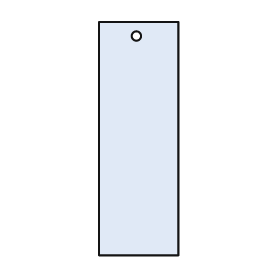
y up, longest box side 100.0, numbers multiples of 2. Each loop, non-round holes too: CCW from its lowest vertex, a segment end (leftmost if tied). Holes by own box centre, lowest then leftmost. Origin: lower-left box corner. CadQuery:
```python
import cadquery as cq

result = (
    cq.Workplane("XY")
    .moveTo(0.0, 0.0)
    .lineTo(34.0, 0.0)
    .lineTo(34.0, 100.0)
    .lineTo(0.0, 100.0)
    .close()
    .moveTo(16.0, 94.0)
    .circle(2.0)
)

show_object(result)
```